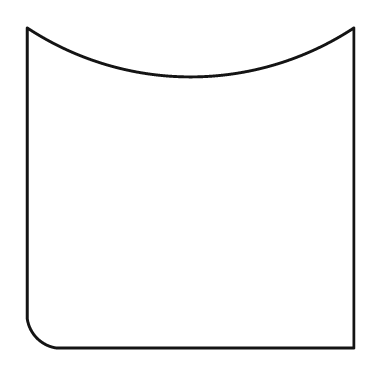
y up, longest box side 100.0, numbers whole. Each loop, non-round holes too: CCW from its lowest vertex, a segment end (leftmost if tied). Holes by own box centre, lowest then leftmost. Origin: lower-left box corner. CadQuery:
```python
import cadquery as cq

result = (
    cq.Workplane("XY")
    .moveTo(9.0, 0.0)
    .lineTo(100.0, 0.0)
    .lineTo(100.0, 98.0)
    .threePointArc((50.0, 83.0), (0.0, 98.0))
    .lineTo(0.0, 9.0)
    .threePointArc((3.0, 3.0), (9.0, 0.0))
    .close()
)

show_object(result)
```